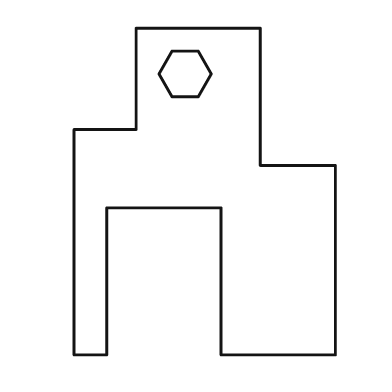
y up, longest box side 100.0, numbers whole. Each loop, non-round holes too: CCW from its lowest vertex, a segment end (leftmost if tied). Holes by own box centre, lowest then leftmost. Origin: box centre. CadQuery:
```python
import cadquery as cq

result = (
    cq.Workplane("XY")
    .moveTo(-40.0, -50.0)
    .lineTo(-30.0, -50.0)
    .lineTo(-30.0, -5.0)
    .lineTo(5.0, -5.0)
    .lineTo(5.0, -50.0)
    .lineTo(40.0, -50.0)
    .lineTo(40.0, 8.0)
    .lineTo(17.0, 8.0)
    .lineTo(17.0, 50.0)
    .lineTo(-21.0, 50.0)
    .lineTo(-21.0, 19.0)
    .lineTo(-40.0, 19.0)
    .close()
    .moveTo(-10.0, 29.0)
    .lineTo(-2.0, 29.0)
    .lineTo(2.0, 36.0)
    .lineTo(-2.0, 43.0)
    .lineTo(-10.0, 43.0)
    .lineTo(-14.0, 36.0)
    .close()
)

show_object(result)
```